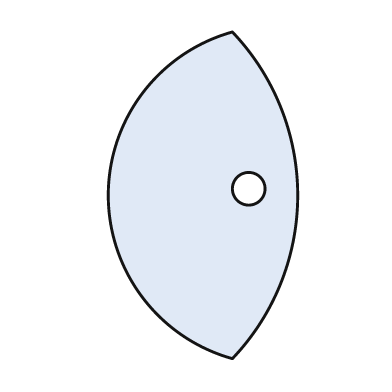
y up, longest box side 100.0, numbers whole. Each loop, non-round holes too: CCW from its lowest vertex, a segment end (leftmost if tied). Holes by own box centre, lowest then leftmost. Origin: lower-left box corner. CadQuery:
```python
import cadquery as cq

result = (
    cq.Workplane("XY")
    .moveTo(38.0, 0.0)
    .threePointArc((58.0, 50.0), (38.0, 100.0))
    .threePointArc((0.0, 50.0), (38.0, 0.0))
    .close()
    .moveTo(43.0, 52.0)
    .circle(5.0)
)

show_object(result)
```